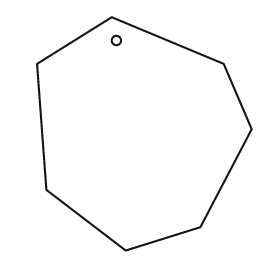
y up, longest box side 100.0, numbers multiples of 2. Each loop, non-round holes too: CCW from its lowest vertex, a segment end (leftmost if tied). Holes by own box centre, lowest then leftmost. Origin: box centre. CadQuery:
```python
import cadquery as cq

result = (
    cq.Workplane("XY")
    .moveTo(-8.0, -50.0)
    .lineTo(24.0, -40.0)
    .lineTo(46.0, 2.0)
    .lineTo(34.0, 30.0)
    .lineTo(-14.0, 50.0)
    .lineTo(-46.0, 30.0)
    .lineTo(-42.0, -24.0)
    .close()
    .moveTo(-12.0, 40.0)
    .circle(2.0)
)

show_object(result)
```